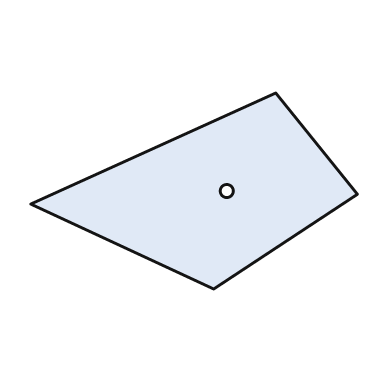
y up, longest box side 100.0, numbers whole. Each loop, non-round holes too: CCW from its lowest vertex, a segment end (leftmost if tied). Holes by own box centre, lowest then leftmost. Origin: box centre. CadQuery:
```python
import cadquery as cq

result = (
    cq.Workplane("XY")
    .moveTo(6.0, -30.0)
    .lineTo(50.0, -1.0)
    .lineTo(25.0, 30.0)
    .lineTo(-50.0, -4.0)
    .close()
    .moveTo(10.0, 0.0)
    .circle(2.0)
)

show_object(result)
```